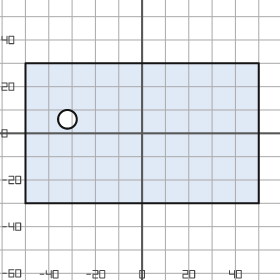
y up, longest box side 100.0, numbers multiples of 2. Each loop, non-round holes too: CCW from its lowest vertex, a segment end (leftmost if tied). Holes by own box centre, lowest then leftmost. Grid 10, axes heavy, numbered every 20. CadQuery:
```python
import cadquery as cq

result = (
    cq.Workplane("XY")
    .moveTo(-50.0, -30.0)
    .lineTo(50.0, -30.0)
    .lineTo(50.0, 30.0)
    .lineTo(-50.0, 30.0)
    .close()
    .moveTo(-32.0, 6.0)
    .circle(4.0)
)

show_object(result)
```